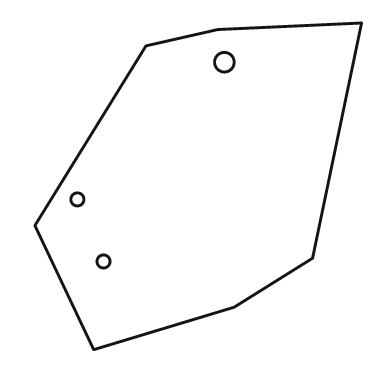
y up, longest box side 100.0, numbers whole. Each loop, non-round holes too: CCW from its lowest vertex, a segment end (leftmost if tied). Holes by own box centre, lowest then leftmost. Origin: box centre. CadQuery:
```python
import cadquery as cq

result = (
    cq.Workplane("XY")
    .moveTo(-32.0, -50.0)
    .lineTo(11.0, -37.0)
    .lineTo(35.0, -22.0)
    .lineTo(50.0, 50.0)
    .lineTo(6.0, 48.0)
    .lineTo(-16.0, 43.0)
    .lineTo(-50.0, -12.0)
    .close()
    .moveTo(-29.0, -23.0)
    .circle(2.0)
    .moveTo(-37.0, -4.0)
    .circle(2.0)
    .moveTo(8.0, 38.0)
    .circle(3.0)
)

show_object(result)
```